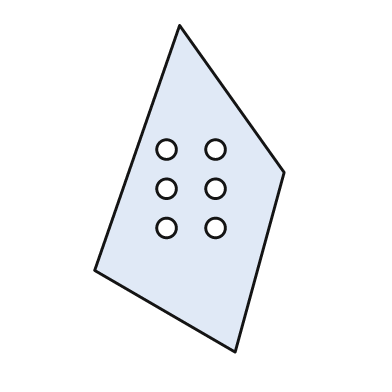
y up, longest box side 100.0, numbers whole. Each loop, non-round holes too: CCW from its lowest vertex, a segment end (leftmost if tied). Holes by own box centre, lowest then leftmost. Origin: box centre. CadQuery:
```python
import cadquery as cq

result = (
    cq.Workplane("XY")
    .moveTo(14.0, -50.0)
    .lineTo(29.0, 5.0)
    .lineTo(-3.0, 50.0)
    .lineTo(-29.0, -25.0)
    .close()
    .moveTo(-7.0, -12.0)
    .circle(3.0)
    .moveTo(8.0, -12.0)
    .circle(3.0)
    .moveTo(-7.0, 0.0)
    .circle(3.0)
    .moveTo(8.0, 0.0)
    .circle(3.0)
    .moveTo(-7.0, 12.0)
    .circle(3.0)
    .moveTo(8.0, 12.0)
    .circle(3.0)
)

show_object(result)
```